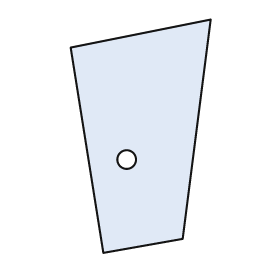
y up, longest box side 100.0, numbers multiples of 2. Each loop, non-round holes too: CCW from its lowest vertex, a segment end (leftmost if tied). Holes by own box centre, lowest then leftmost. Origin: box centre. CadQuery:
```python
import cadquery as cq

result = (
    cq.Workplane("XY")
    .moveTo(-16.0, -50.0)
    .lineTo(18.0, -44.0)
    .lineTo(30.0, 50.0)
    .lineTo(-30.0, 38.0)
    .close()
    .moveTo(-6.0, -10.0)
    .circle(4.0)
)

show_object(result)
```